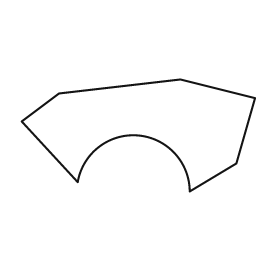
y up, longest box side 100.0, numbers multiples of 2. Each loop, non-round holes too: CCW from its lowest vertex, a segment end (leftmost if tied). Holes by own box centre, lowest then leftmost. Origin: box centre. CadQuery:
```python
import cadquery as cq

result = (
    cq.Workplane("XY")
    .moveTo(22.0, -24.0)
    .lineTo(42.0, -12.0)
    .lineTo(50.0, 16.0)
    .lineTo(18.0, 24.0)
    .lineTo(-34.0, 18.0)
    .lineTo(-50.0, 6.0)
    .lineTo(-26.0, -20.0)
    .threePointArc((0.0, 0.0), (22.0, -24.0))
    .close()
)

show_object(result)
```